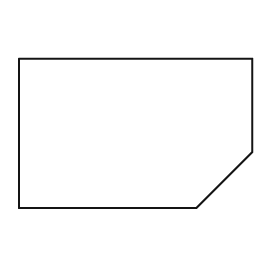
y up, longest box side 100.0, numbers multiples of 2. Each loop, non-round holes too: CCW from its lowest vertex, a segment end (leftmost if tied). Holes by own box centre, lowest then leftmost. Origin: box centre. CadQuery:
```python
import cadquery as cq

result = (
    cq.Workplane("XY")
    .moveTo(-50.0, -32.0)
    .lineTo(26.0, -32.0)
    .lineTo(50.0, -8.0)
    .lineTo(50.0, 32.0)
    .lineTo(-50.0, 32.0)
    .close()
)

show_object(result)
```